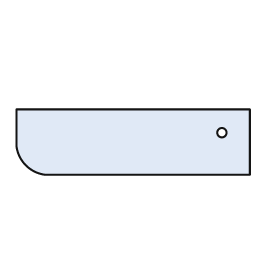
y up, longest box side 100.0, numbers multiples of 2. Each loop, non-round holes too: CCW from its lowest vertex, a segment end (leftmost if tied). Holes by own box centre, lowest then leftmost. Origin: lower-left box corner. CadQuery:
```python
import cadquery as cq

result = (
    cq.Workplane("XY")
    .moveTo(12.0, 0.0)
    .lineTo(100.0, 0.0)
    .lineTo(100.0, 28.0)
    .lineTo(0.0, 28.0)
    .lineTo(0.0, 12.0)
    .threePointArc((4.0, 4.0), (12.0, 0.0))
    .close()
    .moveTo(88.0, 18.0)
    .circle(2.0)
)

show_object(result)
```